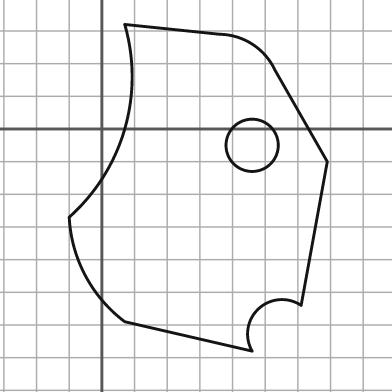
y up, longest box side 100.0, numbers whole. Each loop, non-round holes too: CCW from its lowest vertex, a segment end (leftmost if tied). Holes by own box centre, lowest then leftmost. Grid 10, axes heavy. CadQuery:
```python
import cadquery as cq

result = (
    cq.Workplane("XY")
    .moveTo(46.0, -68.0)
    .threePointArc((48.0, -55.0), (61.0, -54.0))
    .lineTo(69.0, -10.0)
    .lineTo(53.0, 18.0)
    .threePointArc((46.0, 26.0), (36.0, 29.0))
    .lineTo(7.0, 32.0)
    .threePointArc((7.0, 0.0), (-10.0, -27.0))
    .threePointArc((-5.0, -45.0), (7.0, -59.0))
    .close()
    .moveTo(46.0, -5.0)
    .circle(8.0)
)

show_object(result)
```